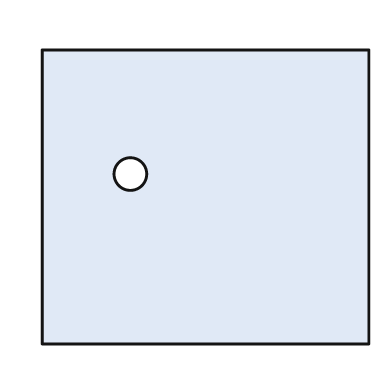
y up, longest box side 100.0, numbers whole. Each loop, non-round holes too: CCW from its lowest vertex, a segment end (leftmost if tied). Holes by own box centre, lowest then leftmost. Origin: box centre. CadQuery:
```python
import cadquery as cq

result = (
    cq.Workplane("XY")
    .moveTo(-50.0, -45.0)
    .lineTo(50.0, -45.0)
    .lineTo(50.0, 45.0)
    .lineTo(-50.0, 45.0)
    .close()
    .moveTo(-23.0, 7.0)
    .circle(5.0)
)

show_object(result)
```